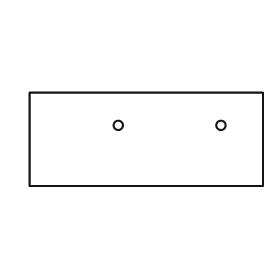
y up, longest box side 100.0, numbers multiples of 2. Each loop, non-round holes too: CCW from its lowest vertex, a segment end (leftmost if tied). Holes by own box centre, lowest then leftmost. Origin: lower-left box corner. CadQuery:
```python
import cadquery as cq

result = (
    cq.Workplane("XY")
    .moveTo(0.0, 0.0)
    .lineTo(100.0, 0.0)
    .lineTo(100.0, 40.0)
    .lineTo(0.0, 40.0)
    .close()
    .moveTo(38.0, 26.0)
    .circle(2.0)
    .moveTo(82.0, 26.0)
    .circle(2.0)
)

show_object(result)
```